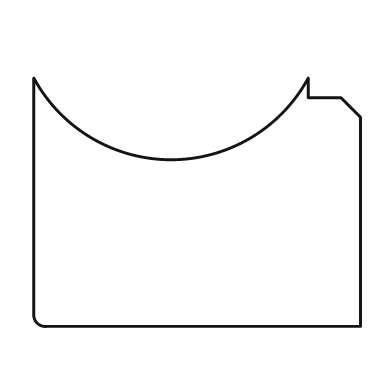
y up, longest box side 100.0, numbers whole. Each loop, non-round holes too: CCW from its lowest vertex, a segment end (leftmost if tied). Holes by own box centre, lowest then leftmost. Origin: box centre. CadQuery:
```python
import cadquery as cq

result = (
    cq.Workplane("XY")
    .moveTo(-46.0, -38.0)
    .lineTo(50.0, -38.0)
    .lineTo(50.0, 26.0)
    .lineTo(44.0, 32.0)
    .lineTo(34.0, 32.0)
    .lineTo(34.0, 38.0)
    .threePointArc((-8.0, 13.0), (-50.0, 38.0))
    .lineTo(-50.0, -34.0)
    .threePointArc((-49.0, -37.0), (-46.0, -38.0))
    .close()
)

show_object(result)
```